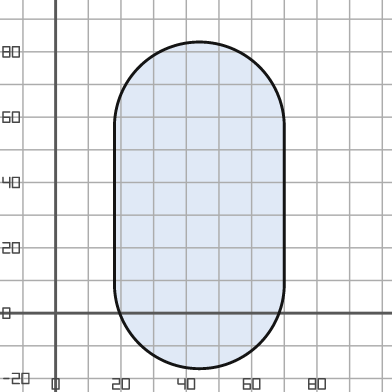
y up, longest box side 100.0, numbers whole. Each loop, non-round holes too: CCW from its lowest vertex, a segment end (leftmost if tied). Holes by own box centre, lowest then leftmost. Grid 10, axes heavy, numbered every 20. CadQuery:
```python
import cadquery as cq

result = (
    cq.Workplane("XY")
    .moveTo(18.0, 9.0)
    .threePointArc((44.0, -17.0), (70.0, 9.0))
    .lineTo(70.0, 57.0)
    .threePointArc((44.0, 83.0), (18.0, 57.0))
    .close()
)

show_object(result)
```